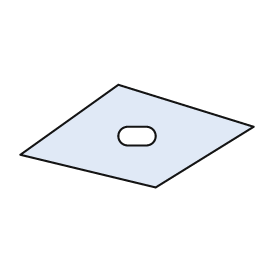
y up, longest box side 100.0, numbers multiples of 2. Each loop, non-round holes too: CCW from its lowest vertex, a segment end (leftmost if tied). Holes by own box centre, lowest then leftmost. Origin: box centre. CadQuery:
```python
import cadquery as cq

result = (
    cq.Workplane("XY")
    .moveTo(8.0, -22.0)
    .lineTo(50.0, 4.0)
    .lineTo(-8.0, 22.0)
    .lineTo(-50.0, -8.0)
    .close()
    .moveTo(-4.0, -4.0)
    .lineTo(4.0, -4.0)
    .threePointArc((8.0, 0.0), (4.0, 4.0))
    .lineTo(-4.0, 4.0)
    .threePointArc((-8.0, 0.0), (-4.0, -4.0))
    .close()
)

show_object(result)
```